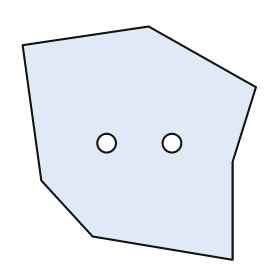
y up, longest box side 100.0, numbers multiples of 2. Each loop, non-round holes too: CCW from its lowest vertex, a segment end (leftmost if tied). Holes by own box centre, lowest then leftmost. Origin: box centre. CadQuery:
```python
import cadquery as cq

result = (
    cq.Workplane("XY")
    .moveTo(40.0, -50.0)
    .lineTo(40.0, -8.0)
    .lineTo(50.0, 24.0)
    .lineTo(4.0, 50.0)
    .lineTo(-50.0, 42.0)
    .lineTo(-42.0, -16.0)
    .lineTo(-20.0, -40.0)
    .close()
    .moveTo(-14.0, 0.0)
    .circle(4.0)
    .moveTo(14.0, 0.0)
    .circle(4.0)
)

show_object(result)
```